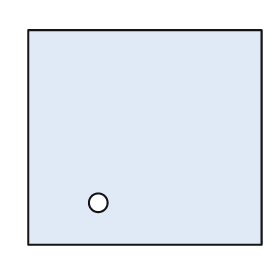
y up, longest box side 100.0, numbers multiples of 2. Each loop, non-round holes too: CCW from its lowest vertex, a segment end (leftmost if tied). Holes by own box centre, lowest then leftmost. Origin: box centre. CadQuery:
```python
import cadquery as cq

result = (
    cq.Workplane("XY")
    .moveTo(-50.0, -46.0)
    .lineTo(50.0, -46.0)
    .lineTo(50.0, 46.0)
    .lineTo(-50.0, 46.0)
    .close()
    .moveTo(-20.0, -28.0)
    .circle(4.0)
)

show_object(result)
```